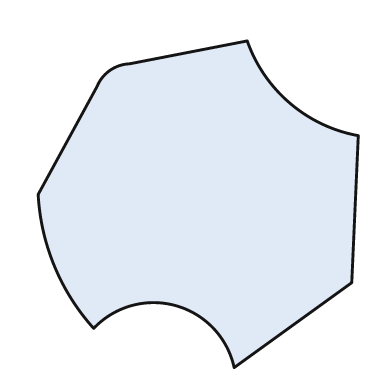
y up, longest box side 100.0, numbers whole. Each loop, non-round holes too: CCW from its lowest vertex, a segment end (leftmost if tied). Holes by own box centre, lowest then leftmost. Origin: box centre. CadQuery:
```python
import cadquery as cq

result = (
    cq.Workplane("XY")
    .moveTo(11.0, -50.0)
    .lineTo(47.0, -24.0)
    .lineTo(49.0, 21.0)
    .threePointArc((28.0, 31.0), (15.0, 50.0))
    .lineTo(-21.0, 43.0)
    .threePointArc((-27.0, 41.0), (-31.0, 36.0))
    .lineTo(-49.0, 3.0)
    .threePointArc((-44.0, -19.0), (-32.0, -38.0))
    .threePointArc((-7.0, -31.0), (11.0, -50.0))
    .close()
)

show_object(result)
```